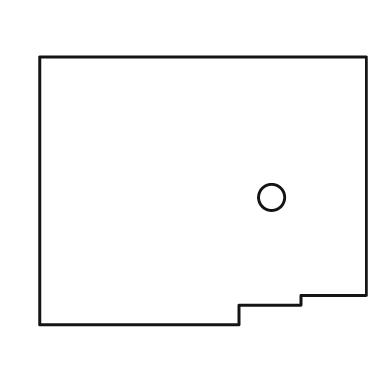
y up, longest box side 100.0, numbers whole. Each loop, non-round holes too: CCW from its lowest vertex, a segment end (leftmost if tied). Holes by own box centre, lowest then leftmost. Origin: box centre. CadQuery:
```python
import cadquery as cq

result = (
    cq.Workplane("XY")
    .moveTo(-50.0, -41.0)
    .lineTo(11.0, -41.0)
    .lineTo(11.0, -35.0)
    .lineTo(30.0, -35.0)
    .lineTo(30.0, -32.0)
    .lineTo(50.0, -32.0)
    .lineTo(50.0, 41.0)
    .lineTo(-50.0, 41.0)
    .close()
    .moveTo(21.0, -2.0)
    .circle(4.0)
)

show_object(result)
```